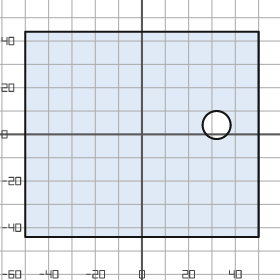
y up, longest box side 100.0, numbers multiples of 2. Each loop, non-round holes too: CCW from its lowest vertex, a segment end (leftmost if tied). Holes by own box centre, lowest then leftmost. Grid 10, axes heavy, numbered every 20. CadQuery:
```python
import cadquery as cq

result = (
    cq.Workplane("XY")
    .moveTo(-50.0, -44.0)
    .lineTo(50.0, -44.0)
    .lineTo(50.0, 44.0)
    .lineTo(-50.0, 44.0)
    .close()
    .moveTo(32.0, 4.0)
    .circle(6.0)
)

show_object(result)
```